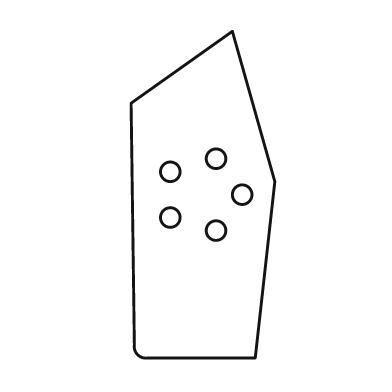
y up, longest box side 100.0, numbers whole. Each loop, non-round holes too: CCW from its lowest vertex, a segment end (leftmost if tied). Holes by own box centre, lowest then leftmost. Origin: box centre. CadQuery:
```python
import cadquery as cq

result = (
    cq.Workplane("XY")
    .moveTo(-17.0, -50.0)
    .lineTo(16.0, -50.0)
    .lineTo(22.0, 4.0)
    .lineTo(9.0, 50.0)
    .lineTo(-22.0, 28.0)
    .lineTo(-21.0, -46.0)
    .threePointArc((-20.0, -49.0), (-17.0, -50.0))
    .close()
    .moveTo(4.0, -11.0)
    .circle(3.0)
    .moveTo(-10.0, -7.0)
    .circle(3.0)
    .moveTo(12.0, 0.0)
    .circle(3.0)
    .moveTo(-10.0, 7.0)
    .circle(3.0)
    .moveTo(4.0, 11.0)
    .circle(3.0)
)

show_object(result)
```